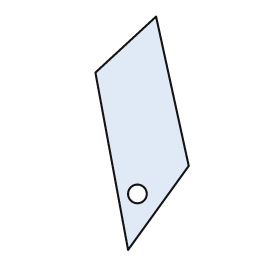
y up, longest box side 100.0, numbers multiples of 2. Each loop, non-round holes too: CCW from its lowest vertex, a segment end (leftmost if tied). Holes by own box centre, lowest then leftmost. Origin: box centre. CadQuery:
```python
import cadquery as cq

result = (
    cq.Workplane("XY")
    .moveTo(-6.0, -50.0)
    .lineTo(20.0, -14.0)
    .lineTo(6.0, 50.0)
    .lineTo(-20.0, 26.0)
    .close()
    .moveTo(-2.0, -26.0)
    .circle(4.0)
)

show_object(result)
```